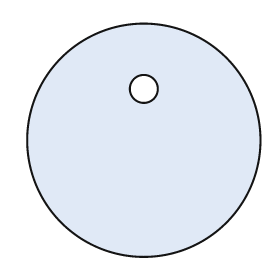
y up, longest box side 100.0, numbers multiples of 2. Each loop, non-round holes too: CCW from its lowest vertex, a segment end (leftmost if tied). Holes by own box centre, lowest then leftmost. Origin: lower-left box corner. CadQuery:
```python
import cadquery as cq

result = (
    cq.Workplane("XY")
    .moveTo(50.0, 50.0)
    .circle(50.0)
    .moveTo(50.0, 72.0)
    .circle(6.0)
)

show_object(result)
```